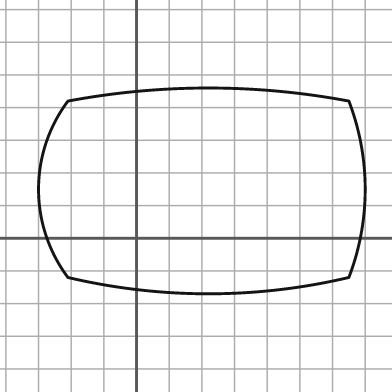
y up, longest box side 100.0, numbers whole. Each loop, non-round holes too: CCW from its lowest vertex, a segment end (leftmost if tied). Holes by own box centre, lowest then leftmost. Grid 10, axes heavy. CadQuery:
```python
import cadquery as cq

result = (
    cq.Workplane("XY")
    .moveTo(-21.0, -12.0)
    .threePointArc((22.0, -17.0), (65.0, -12.0))
    .threePointArc((70.0, 15.0), (65.0, 42.0))
    .threePointArc((22.0, 46.0), (-21.0, 42.0))
    .threePointArc((-30.0, 15.0), (-21.0, -12.0))
    .close()
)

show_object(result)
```